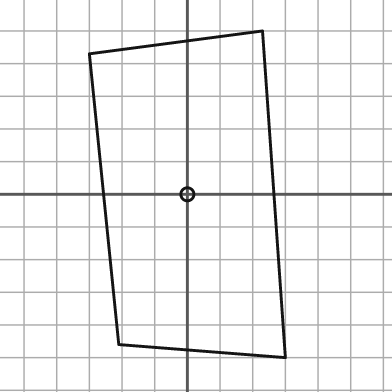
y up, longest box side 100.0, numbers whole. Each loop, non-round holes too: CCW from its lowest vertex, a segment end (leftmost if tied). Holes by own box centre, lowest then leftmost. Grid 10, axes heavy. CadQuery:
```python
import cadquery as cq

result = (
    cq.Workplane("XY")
    .moveTo(30.0, -50.0)
    .lineTo(23.0, 50.0)
    .lineTo(-30.0, 43.0)
    .lineTo(-21.0, -46.0)
    .close()
    .moveTo(0.0, 0.0)
    .circle(2.0)
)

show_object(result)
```